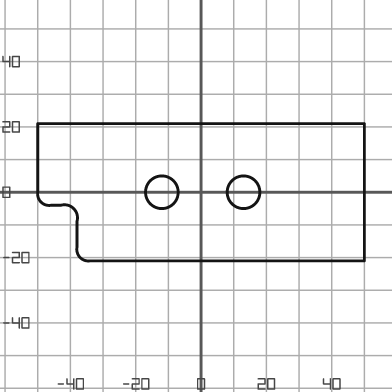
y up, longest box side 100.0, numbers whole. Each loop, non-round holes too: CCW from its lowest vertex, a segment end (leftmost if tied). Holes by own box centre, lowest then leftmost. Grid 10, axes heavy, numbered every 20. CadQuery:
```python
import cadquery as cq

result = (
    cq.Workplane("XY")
    .moveTo(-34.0, -21.0)
    .lineTo(50.0, -21.0)
    .lineTo(50.0, 21.0)
    .lineTo(-50.0, 21.0)
    .lineTo(-50.0, 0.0)
    .threePointArc((-49.0, -3.0), (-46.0, -4.0))
    .lineTo(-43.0, -4.0)
    .threePointArc((-39.0, -5.0), (-38.0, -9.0))
    .lineTo(-38.0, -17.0)
    .threePointArc((-37.0, -20.0), (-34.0, -21.0))
    .close()
    .moveTo(-12.0, 0.0)
    .circle(5.0)
    .moveTo(13.0, 0.0)
    .circle(5.0)
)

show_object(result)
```